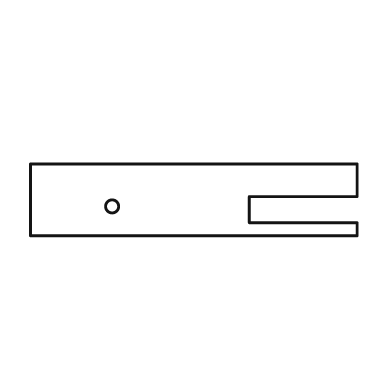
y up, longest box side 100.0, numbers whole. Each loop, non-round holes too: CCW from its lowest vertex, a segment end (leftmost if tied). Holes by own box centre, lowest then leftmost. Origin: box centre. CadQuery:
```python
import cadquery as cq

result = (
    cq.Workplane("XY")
    .moveTo(-50.0, -11.0)
    .lineTo(50.0, -11.0)
    .lineTo(50.0, -7.0)
    .lineTo(17.0, -7.0)
    .lineTo(17.0, 1.0)
    .lineTo(50.0, 1.0)
    .lineTo(50.0, 11.0)
    .lineTo(-50.0, 11.0)
    .close()
    .moveTo(-25.0, -2.0)
    .circle(2.0)
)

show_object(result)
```